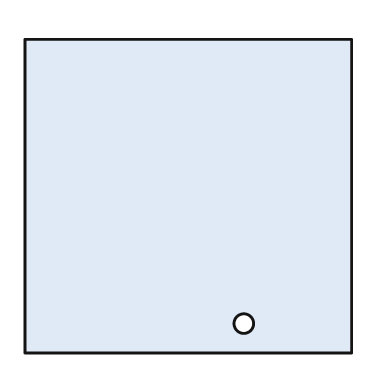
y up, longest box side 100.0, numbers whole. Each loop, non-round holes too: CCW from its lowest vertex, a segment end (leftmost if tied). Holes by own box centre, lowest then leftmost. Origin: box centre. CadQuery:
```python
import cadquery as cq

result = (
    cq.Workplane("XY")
    .moveTo(-50.0, -48.0)
    .lineTo(50.0, -48.0)
    .lineTo(50.0, 48.0)
    .lineTo(-50.0, 48.0)
    .close()
    .moveTo(17.0, -39.0)
    .circle(3.0)
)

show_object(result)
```